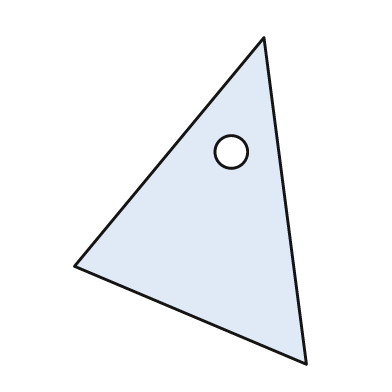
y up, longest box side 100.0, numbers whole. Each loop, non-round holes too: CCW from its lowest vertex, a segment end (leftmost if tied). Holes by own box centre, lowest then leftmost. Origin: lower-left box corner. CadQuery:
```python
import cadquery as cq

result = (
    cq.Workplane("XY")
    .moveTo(71.0, 0.0)
    .lineTo(58.0, 100.0)
    .lineTo(0.0, 30.0)
    .close()
    .moveTo(48.0, 65.0)
    .circle(5.0)
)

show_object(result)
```